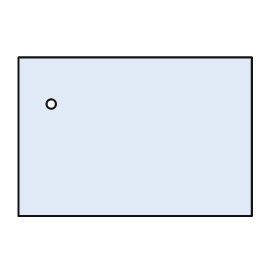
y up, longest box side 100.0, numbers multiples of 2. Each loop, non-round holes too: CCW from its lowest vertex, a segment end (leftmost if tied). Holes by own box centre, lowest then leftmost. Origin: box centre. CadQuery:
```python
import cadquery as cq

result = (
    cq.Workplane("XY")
    .moveTo(-50.0, -34.0)
    .lineTo(50.0, -34.0)
    .lineTo(50.0, 34.0)
    .lineTo(-50.0, 34.0)
    .close()
    .moveTo(-36.0, 14.0)
    .circle(2.0)
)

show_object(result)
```